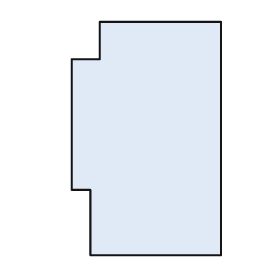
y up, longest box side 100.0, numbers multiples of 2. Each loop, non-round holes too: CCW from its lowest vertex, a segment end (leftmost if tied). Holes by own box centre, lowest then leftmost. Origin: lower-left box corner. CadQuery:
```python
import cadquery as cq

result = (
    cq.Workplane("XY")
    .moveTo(8.0, 0.0)
    .lineTo(64.0, 0.0)
    .lineTo(64.0, 100.0)
    .lineTo(12.0, 100.0)
    .lineTo(12.0, 84.0)
    .lineTo(0.0, 84.0)
    .lineTo(0.0, 28.0)
    .lineTo(8.0, 28.0)
    .close()
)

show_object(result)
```